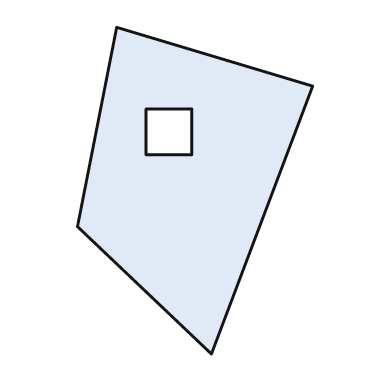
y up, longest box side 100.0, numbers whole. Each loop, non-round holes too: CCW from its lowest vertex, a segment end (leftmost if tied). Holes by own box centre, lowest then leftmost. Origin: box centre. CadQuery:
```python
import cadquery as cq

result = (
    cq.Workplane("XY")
    .moveTo(5.0, -50.0)
    .lineTo(36.0, 32.0)
    .lineTo(-24.0, 50.0)
    .lineTo(-36.0, -11.0)
    .close()
    .moveTo(-15.0, 11.0)
    .lineTo(-1.0, 11.0)
    .lineTo(-1.0, 25.0)
    .lineTo(-15.0, 25.0)
    .close()
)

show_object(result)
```